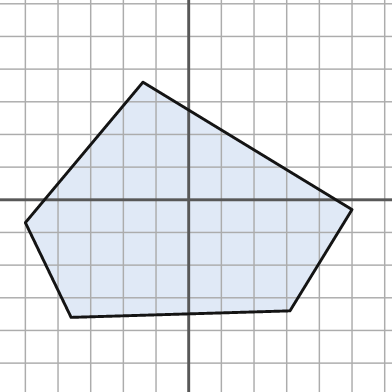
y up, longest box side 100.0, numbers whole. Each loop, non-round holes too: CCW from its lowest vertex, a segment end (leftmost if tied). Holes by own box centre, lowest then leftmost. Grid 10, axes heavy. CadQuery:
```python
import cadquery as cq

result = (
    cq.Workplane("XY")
    .moveTo(-36.0, -36.0)
    .lineTo(31.0, -34.0)
    .lineTo(50.0, -3.0)
    .lineTo(-14.0, 36.0)
    .lineTo(-50.0, -7.0)
    .close()
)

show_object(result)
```